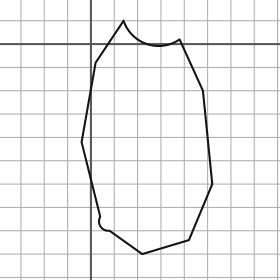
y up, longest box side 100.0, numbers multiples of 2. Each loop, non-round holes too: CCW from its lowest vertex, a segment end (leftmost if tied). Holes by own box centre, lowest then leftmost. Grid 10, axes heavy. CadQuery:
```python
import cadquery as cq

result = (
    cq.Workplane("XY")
    .moveTo(22.0, -90.0)
    .lineTo(42.0, -84.0)
    .lineTo(52.0, -60.0)
    .lineTo(48.0, -20.0)
    .lineTo(38.0, 2.0)
    .threePointArc((24.0, 0.0), (14.0, 10.0))
    .lineTo(2.0, -8.0)
    .lineTo(-4.0, -42.0)
    .lineTo(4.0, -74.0)
    .threePointArc((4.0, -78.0), (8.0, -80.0))
    .close()
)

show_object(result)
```